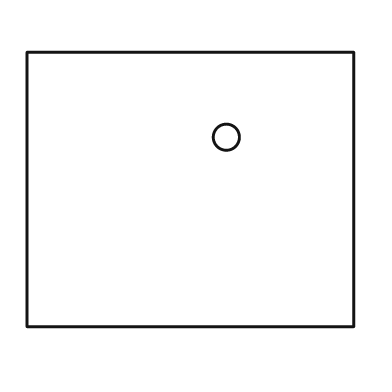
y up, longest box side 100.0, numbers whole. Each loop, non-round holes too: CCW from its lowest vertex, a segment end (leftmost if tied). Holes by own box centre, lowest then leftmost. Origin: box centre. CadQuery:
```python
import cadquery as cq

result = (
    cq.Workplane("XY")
    .moveTo(-50.0, -42.0)
    .lineTo(50.0, -42.0)
    .lineTo(50.0, 42.0)
    .lineTo(-50.0, 42.0)
    .close()
    .moveTo(11.0, 16.0)
    .circle(4.0)
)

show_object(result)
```